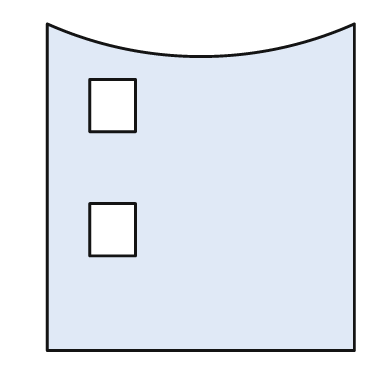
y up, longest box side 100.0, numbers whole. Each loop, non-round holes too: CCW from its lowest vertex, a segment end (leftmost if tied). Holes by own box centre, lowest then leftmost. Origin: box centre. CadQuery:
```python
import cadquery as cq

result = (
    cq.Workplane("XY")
    .moveTo(-47.0, -50.0)
    .lineTo(47.0, -50.0)
    .lineTo(47.0, 50.0)
    .threePointArc((0.0, 40.0), (-47.0, 50.0))
    .close()
    .moveTo(-34.0, -21.0)
    .lineTo(-20.0, -21.0)
    .lineTo(-20.0, -5.0)
    .lineTo(-34.0, -5.0)
    .close()
    .moveTo(-34.0, 17.0)
    .lineTo(-20.0, 17.0)
    .lineTo(-20.0, 33.0)
    .lineTo(-34.0, 33.0)
    .close()
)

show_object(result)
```